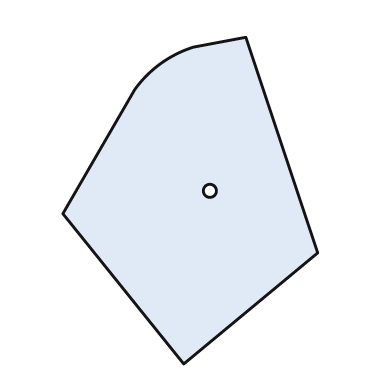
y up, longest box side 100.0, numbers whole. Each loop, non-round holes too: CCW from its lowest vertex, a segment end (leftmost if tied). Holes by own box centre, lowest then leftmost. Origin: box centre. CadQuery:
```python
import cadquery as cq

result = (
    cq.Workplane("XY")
    .moveTo(-2.0, -50.0)
    .lineTo(39.0, -16.0)
    .lineTo(17.0, 50.0)
    .lineTo(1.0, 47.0)
    .threePointArc((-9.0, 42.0), (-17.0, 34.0))
    .lineTo(-39.0, -4.0)
    .close()
    .moveTo(6.0, 3.0)
    .circle(2.0)
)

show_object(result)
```